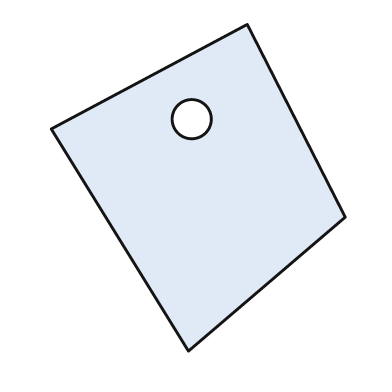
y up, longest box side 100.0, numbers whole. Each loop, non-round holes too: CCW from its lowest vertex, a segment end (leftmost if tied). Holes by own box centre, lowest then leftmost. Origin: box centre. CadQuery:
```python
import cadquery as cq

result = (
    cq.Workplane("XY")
    .moveTo(-3.0, -50.0)
    .lineTo(45.0, -9.0)
    .lineTo(15.0, 50.0)
    .lineTo(-45.0, 18.0)
    .close()
    .moveTo(-2.0, 21.0)
    .circle(6.0)
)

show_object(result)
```